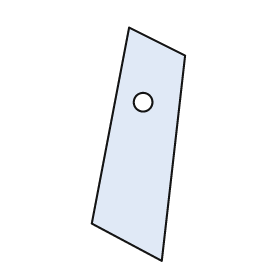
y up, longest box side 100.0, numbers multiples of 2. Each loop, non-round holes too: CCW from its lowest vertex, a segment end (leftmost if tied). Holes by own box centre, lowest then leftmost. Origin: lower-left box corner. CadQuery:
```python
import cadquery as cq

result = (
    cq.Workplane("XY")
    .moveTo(30.0, 0.0)
    .lineTo(40.0, 88.0)
    .lineTo(16.0, 100.0)
    .lineTo(0.0, 16.0)
    .close()
    .moveTo(22.0, 68.0)
    .circle(4.0)
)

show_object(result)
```